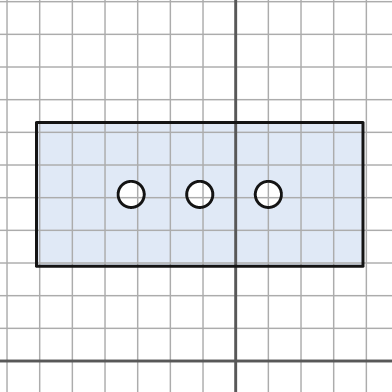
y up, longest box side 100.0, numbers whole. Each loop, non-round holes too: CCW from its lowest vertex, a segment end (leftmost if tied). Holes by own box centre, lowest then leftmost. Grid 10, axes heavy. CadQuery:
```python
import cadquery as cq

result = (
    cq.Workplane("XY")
    .moveTo(-61.0, 29.0)
    .lineTo(39.0, 29.0)
    .lineTo(39.0, 73.0)
    .lineTo(-61.0, 73.0)
    .close()
    .moveTo(-32.0, 51.0)
    .circle(4.0)
    .moveTo(-11.0, 51.0)
    .circle(4.0)
    .moveTo(10.0, 51.0)
    .circle(4.0)
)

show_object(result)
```